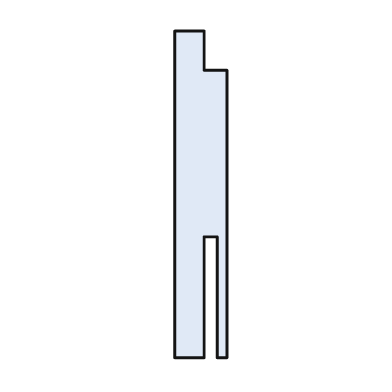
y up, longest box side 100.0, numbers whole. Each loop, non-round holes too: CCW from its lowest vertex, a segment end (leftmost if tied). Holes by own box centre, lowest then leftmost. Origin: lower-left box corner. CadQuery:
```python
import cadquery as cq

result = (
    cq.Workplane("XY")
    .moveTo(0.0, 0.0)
    .lineTo(9.0, 0.0)
    .lineTo(9.0, 37.0)
    .lineTo(13.0, 37.0)
    .lineTo(13.0, 0.0)
    .lineTo(16.0, 0.0)
    .lineTo(16.0, 88.0)
    .lineTo(9.0, 88.0)
    .lineTo(9.0, 100.0)
    .lineTo(0.0, 100.0)
    .close()
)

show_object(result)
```